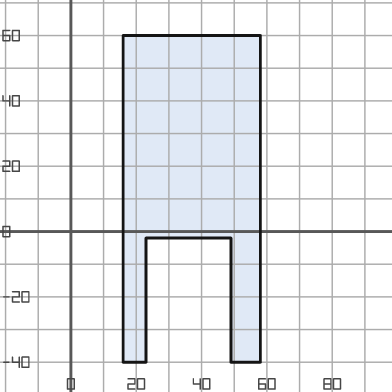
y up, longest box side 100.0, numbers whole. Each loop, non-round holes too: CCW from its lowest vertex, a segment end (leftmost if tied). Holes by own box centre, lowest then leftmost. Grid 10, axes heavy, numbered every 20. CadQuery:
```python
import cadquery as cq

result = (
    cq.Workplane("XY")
    .moveTo(16.0, -40.0)
    .lineTo(23.0, -40.0)
    .lineTo(23.0, -2.0)
    .lineTo(49.0, -2.0)
    .lineTo(49.0, -40.0)
    .lineTo(58.0, -40.0)
    .lineTo(58.0, 60.0)
    .lineTo(16.0, 60.0)
    .close()
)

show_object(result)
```